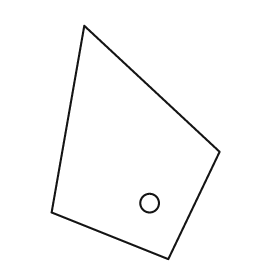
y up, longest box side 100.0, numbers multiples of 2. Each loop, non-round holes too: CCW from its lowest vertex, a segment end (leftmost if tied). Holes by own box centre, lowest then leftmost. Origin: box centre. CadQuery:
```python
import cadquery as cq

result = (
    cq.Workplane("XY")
    .moveTo(14.0, -50.0)
    .lineTo(36.0, -4.0)
    .lineTo(-22.0, 50.0)
    .lineTo(-36.0, -30.0)
    .close()
    .moveTo(6.0, -26.0)
    .circle(4.0)
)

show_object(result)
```